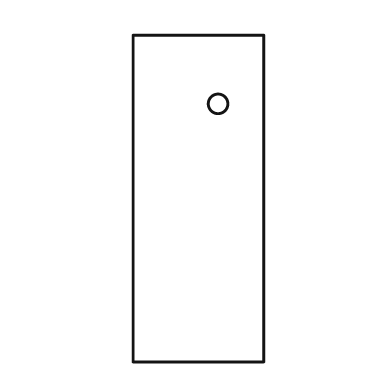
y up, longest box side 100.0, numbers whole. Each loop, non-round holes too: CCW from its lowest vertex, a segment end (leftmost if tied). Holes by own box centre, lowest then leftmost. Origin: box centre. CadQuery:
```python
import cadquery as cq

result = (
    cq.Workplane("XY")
    .moveTo(-20.0, -50.0)
    .lineTo(20.0, -50.0)
    .lineTo(20.0, 50.0)
    .lineTo(-20.0, 50.0)
    .close()
    .moveTo(6.0, 29.0)
    .circle(3.0)
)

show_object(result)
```